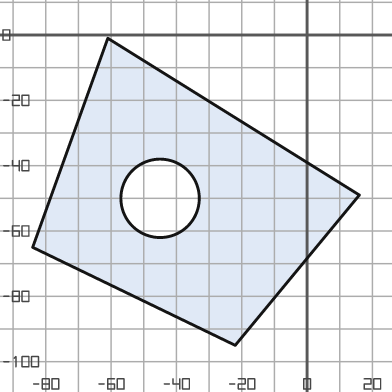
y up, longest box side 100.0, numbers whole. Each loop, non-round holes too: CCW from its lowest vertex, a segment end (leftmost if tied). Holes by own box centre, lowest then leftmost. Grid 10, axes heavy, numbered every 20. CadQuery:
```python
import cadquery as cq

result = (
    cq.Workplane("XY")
    .moveTo(-22.0, -95.0)
    .lineTo(16.0, -49.0)
    .lineTo(-61.0, -1.0)
    .lineTo(-84.0, -65.0)
    .close()
    .moveTo(-45.0, -50.0)
    .circle(12.0)
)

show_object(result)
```